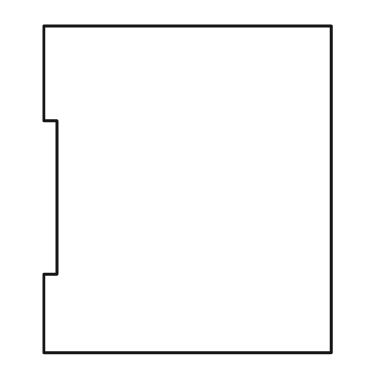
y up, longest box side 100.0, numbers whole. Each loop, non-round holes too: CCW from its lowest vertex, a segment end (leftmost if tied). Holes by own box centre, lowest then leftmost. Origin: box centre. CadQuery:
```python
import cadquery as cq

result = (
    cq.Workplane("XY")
    .moveTo(-44.0, -50.0)
    .lineTo(44.0, -50.0)
    .lineTo(44.0, 50.0)
    .lineTo(-44.0, 50.0)
    .lineTo(-44.0, 21.0)
    .lineTo(-40.0, 21.0)
    .lineTo(-40.0, -26.0)
    .lineTo(-44.0, -26.0)
    .close()
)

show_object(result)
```